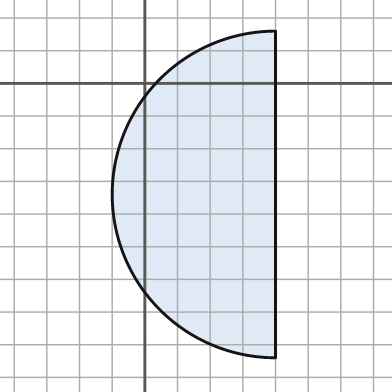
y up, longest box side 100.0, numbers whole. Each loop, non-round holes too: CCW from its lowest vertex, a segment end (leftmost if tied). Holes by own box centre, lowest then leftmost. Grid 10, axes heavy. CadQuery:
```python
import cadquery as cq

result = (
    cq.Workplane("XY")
    .moveTo(40.0, -84.0)
    .lineTo(40.0, 16.0)
    .threePointArc((-10.0, -34.0), (40.0, -84.0))
    .close()
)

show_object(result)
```